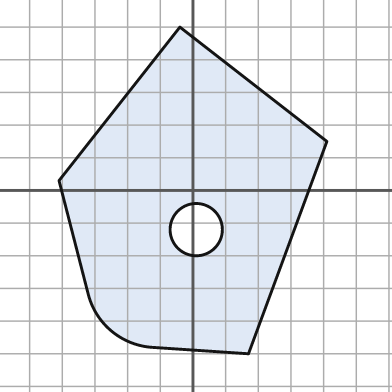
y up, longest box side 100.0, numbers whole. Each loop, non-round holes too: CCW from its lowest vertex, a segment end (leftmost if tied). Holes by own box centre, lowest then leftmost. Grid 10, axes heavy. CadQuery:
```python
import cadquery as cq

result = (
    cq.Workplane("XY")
    .moveTo(17.0, -50.0)
    .lineTo(41.0, 15.0)
    .lineTo(-4.0, 50.0)
    .lineTo(-41.0, 3.0)
    .lineTo(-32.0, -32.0)
    .threePointArc((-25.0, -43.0), (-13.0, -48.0))
    .close()
    .moveTo(1.0, -12.0)
    .circle(8.0)
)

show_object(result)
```